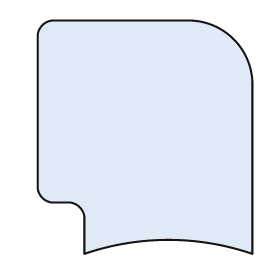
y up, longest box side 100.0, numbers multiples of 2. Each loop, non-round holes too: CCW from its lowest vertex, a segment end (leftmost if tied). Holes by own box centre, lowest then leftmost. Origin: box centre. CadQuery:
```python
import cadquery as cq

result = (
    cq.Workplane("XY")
    .moveTo(-26.0, -50.0)
    .threePointArc((10.0, -44.0), (46.0, -50.0))
    .lineTo(46.0, 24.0)
    .threePointArc((38.0, 42.0), (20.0, 50.0))
    .lineTo(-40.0, 50.0)
    .threePointArc((-44.0, 48.0), (-46.0, 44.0))
    .lineTo(-46.0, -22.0)
    .threePointArc((-44.0, -26.0), (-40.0, -28.0))
    .lineTo(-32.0, -28.0)
    .threePointArc((-28.0, -30.0), (-26.0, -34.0))
    .close()
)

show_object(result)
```